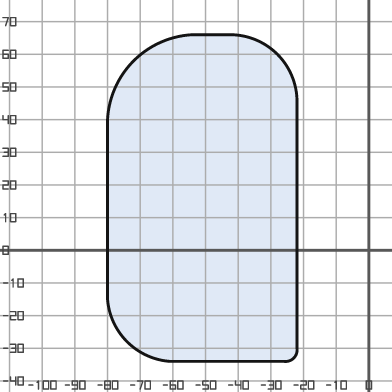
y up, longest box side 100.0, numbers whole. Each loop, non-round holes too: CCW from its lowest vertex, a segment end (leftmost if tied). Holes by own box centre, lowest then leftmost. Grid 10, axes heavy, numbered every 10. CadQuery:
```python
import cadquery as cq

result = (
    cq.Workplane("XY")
    .moveTo(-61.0, -34.0)
    .lineTo(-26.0, -34.0)
    .threePointArc((-23.0, -33.0), (-22.0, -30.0))
    .lineTo(-22.0, 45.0)
    .threePointArc((-28.0, 60.0), (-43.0, 66.0))
    .lineTo(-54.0, 66.0)
    .threePointArc((-72.0, 58.0), (-80.0, 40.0))
    .lineTo(-80.0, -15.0)
    .threePointArc((-74.0, -28.0), (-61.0, -34.0))
    .close()
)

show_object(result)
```